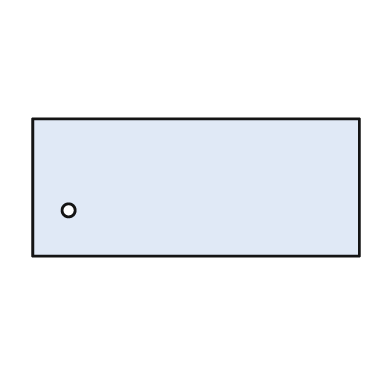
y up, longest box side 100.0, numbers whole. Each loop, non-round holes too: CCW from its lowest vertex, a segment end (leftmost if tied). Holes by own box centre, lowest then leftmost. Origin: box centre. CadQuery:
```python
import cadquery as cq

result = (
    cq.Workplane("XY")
    .moveTo(-50.0, -21.0)
    .lineTo(50.0, -21.0)
    .lineTo(50.0, 21.0)
    .lineTo(-50.0, 21.0)
    .close()
    .moveTo(-39.0, -7.0)
    .circle(2.0)
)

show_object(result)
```